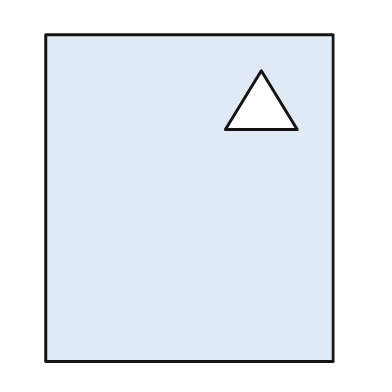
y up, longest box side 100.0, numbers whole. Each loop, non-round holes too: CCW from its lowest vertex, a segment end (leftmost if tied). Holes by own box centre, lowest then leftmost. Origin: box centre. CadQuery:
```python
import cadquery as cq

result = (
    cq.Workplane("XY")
    .moveTo(-44.0, -50.0)
    .lineTo(44.0, -50.0)
    .lineTo(44.0, 50.0)
    .lineTo(-44.0, 50.0)
    .close()
    .moveTo(11.0, 21.0)
    .lineTo(33.0, 21.0)
    .lineTo(22.0, 39.0)
    .close()
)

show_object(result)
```